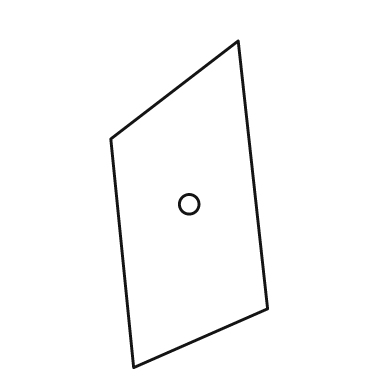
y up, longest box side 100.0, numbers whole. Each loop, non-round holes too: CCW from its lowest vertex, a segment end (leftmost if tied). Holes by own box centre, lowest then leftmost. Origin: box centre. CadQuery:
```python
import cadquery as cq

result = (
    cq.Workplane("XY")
    .moveTo(-17.0, -50.0)
    .lineTo(24.0, -32.0)
    .lineTo(15.0, 50.0)
    .lineTo(-24.0, 20.0)
    .close()
    .moveTo(0.0, 0.0)
    .circle(3.0)
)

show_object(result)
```